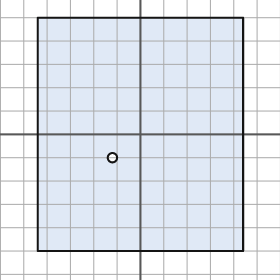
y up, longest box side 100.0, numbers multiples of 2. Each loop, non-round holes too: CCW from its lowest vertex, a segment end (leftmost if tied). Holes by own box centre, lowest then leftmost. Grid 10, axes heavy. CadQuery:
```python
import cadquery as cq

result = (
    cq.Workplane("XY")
    .moveTo(-44.0, -50.0)
    .lineTo(44.0, -50.0)
    .lineTo(44.0, 50.0)
    .lineTo(-44.0, 50.0)
    .close()
    .moveTo(-12.0, -10.0)
    .circle(2.0)
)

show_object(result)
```